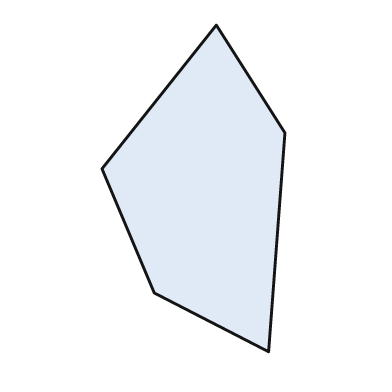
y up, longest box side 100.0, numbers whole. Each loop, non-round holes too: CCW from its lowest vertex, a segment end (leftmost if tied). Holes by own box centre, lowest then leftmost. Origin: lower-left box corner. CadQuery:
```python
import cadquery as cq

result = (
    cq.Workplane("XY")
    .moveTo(51.0, 0.0)
    .lineTo(56.0, 67.0)
    .lineTo(35.0, 100.0)
    .lineTo(0.0, 56.0)
    .lineTo(16.0, 18.0)
    .close()
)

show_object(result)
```